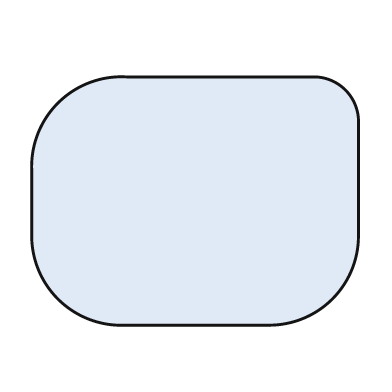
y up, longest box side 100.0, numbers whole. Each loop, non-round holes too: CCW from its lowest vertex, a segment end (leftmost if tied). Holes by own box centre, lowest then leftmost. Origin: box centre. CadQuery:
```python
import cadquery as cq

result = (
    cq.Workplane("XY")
    .moveTo(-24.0, -38.0)
    .lineTo(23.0, -38.0)
    .threePointArc((42.0, -30.0), (50.0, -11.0))
    .lineTo(50.0, 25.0)
    .threePointArc((46.0, 34.0), (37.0, 38.0))
    .lineTo(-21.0, 38.0)
    .threePointArc((-42.0, 30.0), (-50.0, 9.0))
    .lineTo(-50.0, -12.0)
    .threePointArc((-42.0, -30.0), (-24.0, -38.0))
    .close()
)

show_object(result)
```